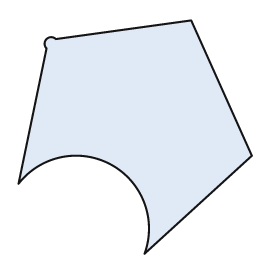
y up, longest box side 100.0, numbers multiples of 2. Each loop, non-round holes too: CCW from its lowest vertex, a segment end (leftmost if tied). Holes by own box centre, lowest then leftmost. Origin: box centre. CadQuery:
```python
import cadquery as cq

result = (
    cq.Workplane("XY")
    .moveTo(4.0, -50.0)
    .lineTo(50.0, -8.0)
    .lineTo(24.0, 50.0)
    .lineTo(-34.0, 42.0)
    .threePointArc((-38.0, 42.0), (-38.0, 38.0))
    .lineTo(-50.0, -20.0)
    .threePointArc((-10.0, -12.0), (4.0, -50.0))
    .close()
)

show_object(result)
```